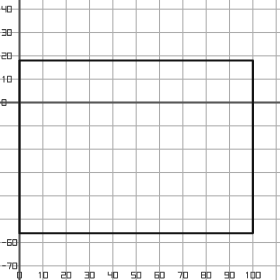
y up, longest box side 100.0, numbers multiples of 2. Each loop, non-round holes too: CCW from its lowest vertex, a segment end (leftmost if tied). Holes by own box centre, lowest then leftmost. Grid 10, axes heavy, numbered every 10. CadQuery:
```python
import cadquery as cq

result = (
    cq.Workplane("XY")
    .moveTo(0.0, -56.0)
    .lineTo(100.0, -56.0)
    .lineTo(100.0, 18.0)
    .lineTo(0.0, 18.0)
    .close()
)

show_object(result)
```